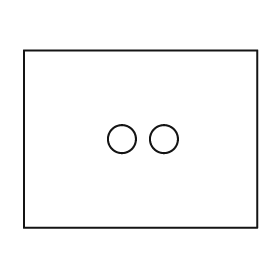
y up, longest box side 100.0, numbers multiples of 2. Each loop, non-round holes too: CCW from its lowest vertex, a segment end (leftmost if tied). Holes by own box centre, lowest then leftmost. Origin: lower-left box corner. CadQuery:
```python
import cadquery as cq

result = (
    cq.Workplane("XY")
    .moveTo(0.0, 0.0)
    .lineTo(100.0, 0.0)
    .lineTo(100.0, 76.0)
    .lineTo(0.0, 76.0)
    .close()
    .moveTo(42.0, 38.0)
    .circle(6.0)
    .moveTo(60.0, 38.0)
    .circle(6.0)
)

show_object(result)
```